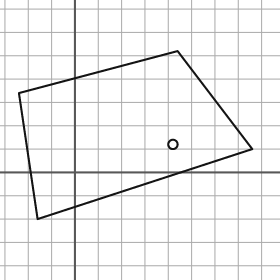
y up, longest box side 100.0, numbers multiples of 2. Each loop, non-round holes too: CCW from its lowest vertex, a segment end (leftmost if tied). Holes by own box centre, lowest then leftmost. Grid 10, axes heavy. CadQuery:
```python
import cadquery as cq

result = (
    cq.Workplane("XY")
    .moveTo(-16.0, -20.0)
    .lineTo(76.0, 10.0)
    .lineTo(44.0, 52.0)
    .lineTo(-24.0, 34.0)
    .close()
    .moveTo(42.0, 12.0)
    .circle(2.0)
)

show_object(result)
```